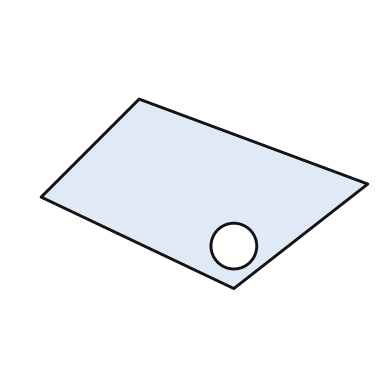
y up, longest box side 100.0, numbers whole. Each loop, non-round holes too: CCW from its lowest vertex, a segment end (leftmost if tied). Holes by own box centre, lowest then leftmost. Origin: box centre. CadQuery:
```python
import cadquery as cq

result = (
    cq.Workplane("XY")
    .moveTo(9.0, -29.0)
    .lineTo(50.0, 3.0)
    .lineTo(-20.0, 29.0)
    .lineTo(-50.0, -1.0)
    .close()
    .moveTo(9.0, -16.0)
    .circle(7.0)
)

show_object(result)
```